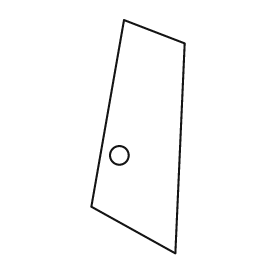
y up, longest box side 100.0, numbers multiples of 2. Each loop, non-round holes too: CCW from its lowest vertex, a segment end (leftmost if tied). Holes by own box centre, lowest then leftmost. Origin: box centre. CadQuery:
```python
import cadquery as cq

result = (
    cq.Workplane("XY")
    .moveTo(16.0, -50.0)
    .lineTo(20.0, 40.0)
    .lineTo(-6.0, 50.0)
    .lineTo(-20.0, -30.0)
    .close()
    .moveTo(-8.0, -8.0)
    .circle(4.0)
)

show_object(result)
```